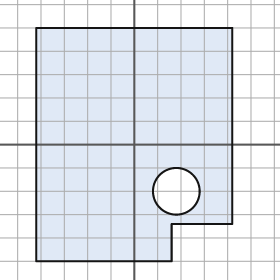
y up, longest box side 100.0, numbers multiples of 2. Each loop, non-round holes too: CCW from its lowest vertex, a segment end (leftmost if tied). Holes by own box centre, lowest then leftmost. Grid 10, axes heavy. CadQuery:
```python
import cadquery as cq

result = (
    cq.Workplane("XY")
    .moveTo(-42.0, -50.0)
    .lineTo(16.0, -50.0)
    .lineTo(16.0, -34.0)
    .lineTo(42.0, -34.0)
    .lineTo(42.0, 50.0)
    .lineTo(-42.0, 50.0)
    .close()
    .moveTo(18.0, -20.0)
    .circle(10.0)
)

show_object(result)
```